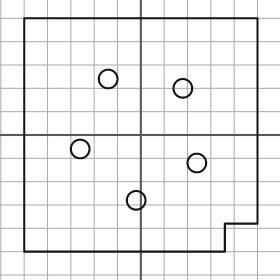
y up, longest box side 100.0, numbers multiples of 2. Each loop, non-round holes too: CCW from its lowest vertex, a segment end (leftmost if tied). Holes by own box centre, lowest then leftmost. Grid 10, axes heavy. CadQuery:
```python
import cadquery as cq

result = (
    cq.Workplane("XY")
    .moveTo(-50.0, -50.0)
    .lineTo(36.0, -50.0)
    .lineTo(36.0, -38.0)
    .lineTo(50.0, -38.0)
    .lineTo(50.0, 50.0)
    .lineTo(-50.0, 50.0)
    .close()
    .moveTo(-2.0, -28.0)
    .circle(4.0)
    .moveTo(24.0, -12.0)
    .circle(4.0)
    .moveTo(-26.0, -6.0)
    .circle(4.0)
    .moveTo(18.0, 20.0)
    .circle(4.0)
    .moveTo(-14.0, 24.0)
    .circle(4.0)
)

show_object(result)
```